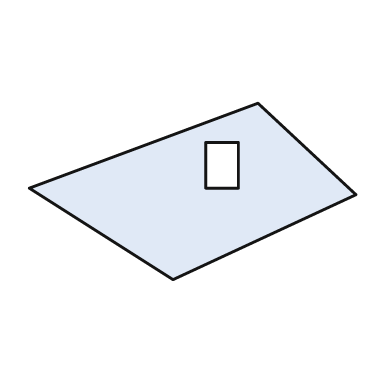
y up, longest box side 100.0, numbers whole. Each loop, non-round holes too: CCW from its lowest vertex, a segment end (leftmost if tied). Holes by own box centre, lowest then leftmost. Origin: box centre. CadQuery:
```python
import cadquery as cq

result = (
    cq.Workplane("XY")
    .moveTo(-6.0, -27.0)
    .lineTo(50.0, -1.0)
    .lineTo(20.0, 27.0)
    .lineTo(-50.0, 1.0)
    .close()
    .moveTo(4.0, 1.0)
    .lineTo(14.0, 1.0)
    .lineTo(14.0, 15.0)
    .lineTo(4.0, 15.0)
    .close()
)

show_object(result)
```